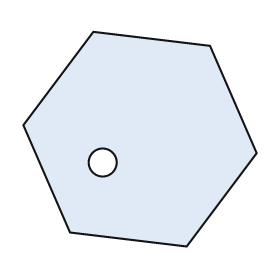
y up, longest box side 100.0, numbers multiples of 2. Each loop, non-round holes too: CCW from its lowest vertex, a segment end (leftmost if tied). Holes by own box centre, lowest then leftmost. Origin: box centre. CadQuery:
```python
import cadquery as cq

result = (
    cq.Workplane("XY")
    .moveTo(20.0, -46.0)
    .lineTo(50.0, -6.0)
    .lineTo(30.0, 40.0)
    .lineTo(-20.0, 46.0)
    .lineTo(-50.0, 6.0)
    .lineTo(-30.0, -40.0)
    .close()
    .moveTo(-16.0, -10.0)
    .circle(6.0)
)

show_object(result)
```